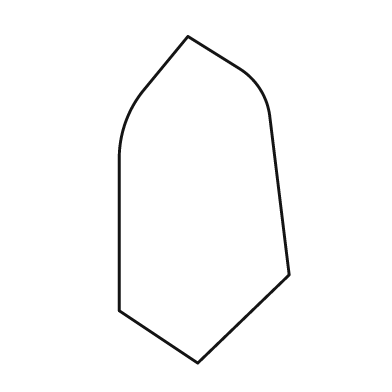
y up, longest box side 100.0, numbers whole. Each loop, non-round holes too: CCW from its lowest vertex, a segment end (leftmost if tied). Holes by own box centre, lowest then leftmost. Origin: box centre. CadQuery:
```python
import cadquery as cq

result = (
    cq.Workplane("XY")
    .moveTo(-2.0, -50.0)
    .lineTo(26.0, -23.0)
    .lineTo(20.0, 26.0)
    .threePointArc((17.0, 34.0), (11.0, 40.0))
    .lineTo(-5.0, 50.0)
    .lineTo(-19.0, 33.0)
    .threePointArc((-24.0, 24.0), (-26.0, 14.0))
    .lineTo(-26.0, -34.0)
    .close()
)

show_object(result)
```